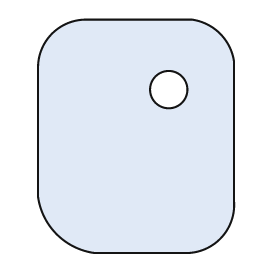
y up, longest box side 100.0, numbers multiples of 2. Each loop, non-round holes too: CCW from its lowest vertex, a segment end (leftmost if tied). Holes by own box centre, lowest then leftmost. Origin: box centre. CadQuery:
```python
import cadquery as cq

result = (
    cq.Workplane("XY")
    .moveTo(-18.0, -50.0)
    .lineTo(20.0, -50.0)
    .threePointArc((36.0, -44.0), (42.0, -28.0))
    .lineTo(42.0, 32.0)
    .threePointArc((36.0, 44.0), (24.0, 50.0))
    .lineTo(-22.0, 50.0)
    .threePointArc((-36.0, 44.0), (-42.0, 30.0))
    .lineTo(-42.0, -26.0)
    .threePointArc((-34.0, -42.0), (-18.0, -50.0))
    .close()
    .moveTo(14.0, 20.0)
    .circle(8.0)
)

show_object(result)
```